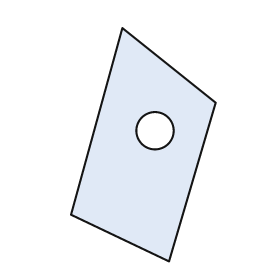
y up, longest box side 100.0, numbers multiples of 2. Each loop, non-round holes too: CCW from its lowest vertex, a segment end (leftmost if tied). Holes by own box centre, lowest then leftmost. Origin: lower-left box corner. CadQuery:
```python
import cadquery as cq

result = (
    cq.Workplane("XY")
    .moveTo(42.0, 0.0)
    .lineTo(62.0, 68.0)
    .lineTo(22.0, 100.0)
    .lineTo(0.0, 20.0)
    .close()
    .moveTo(36.0, 56.0)
    .circle(8.0)
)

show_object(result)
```